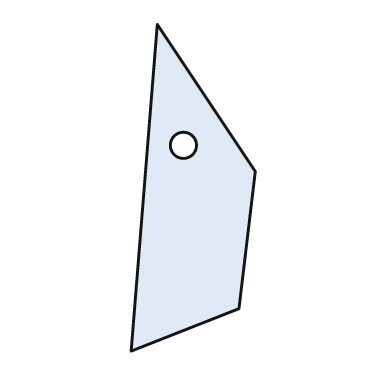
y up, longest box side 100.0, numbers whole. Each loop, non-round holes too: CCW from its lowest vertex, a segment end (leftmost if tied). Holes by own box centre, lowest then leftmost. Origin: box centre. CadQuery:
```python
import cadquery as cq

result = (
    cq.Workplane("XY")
    .moveTo(-19.0, -50.0)
    .lineTo(14.0, -37.0)
    .lineTo(19.0, 5.0)
    .lineTo(-11.0, 50.0)
    .close()
    .moveTo(-3.0, 13.0)
    .circle(4.0)
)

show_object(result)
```